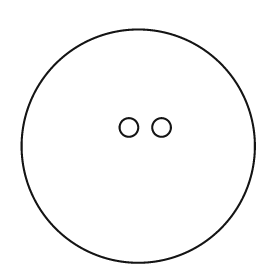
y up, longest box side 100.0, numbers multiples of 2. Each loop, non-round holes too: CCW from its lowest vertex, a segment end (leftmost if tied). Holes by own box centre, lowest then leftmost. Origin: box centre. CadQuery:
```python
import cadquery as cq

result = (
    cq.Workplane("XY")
    .moveTo(0.0, 0.0)
    .circle(50.0)
    .moveTo(-4.0, 8.0)
    .circle(4.0)
    .moveTo(10.0, 8.0)
    .circle(4.0)
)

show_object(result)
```